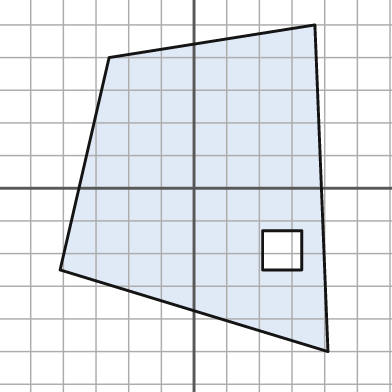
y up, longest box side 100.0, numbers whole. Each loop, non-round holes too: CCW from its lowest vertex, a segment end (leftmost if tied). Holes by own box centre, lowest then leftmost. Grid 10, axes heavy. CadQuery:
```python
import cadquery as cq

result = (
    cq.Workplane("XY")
    .moveTo(41.0, -50.0)
    .lineTo(37.0, 50.0)
    .lineTo(-26.0, 40.0)
    .lineTo(-41.0, -25.0)
    .close()
    .moveTo(21.0, -25.0)
    .lineTo(33.0, -25.0)
    .lineTo(33.0, -13.0)
    .lineTo(21.0, -13.0)
    .close()
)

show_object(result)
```